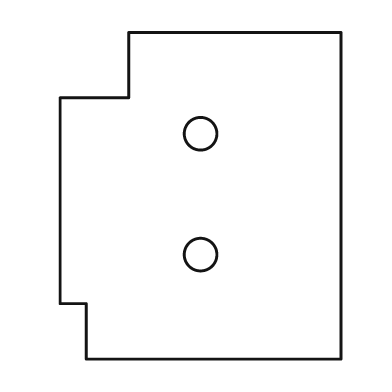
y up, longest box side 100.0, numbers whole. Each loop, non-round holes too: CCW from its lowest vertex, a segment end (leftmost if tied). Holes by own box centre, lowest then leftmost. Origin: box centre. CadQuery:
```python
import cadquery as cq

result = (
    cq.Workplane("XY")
    .moveTo(-35.0, -50.0)
    .lineTo(43.0, -50.0)
    .lineTo(43.0, 50.0)
    .lineTo(-22.0, 50.0)
    .lineTo(-22.0, 30.0)
    .lineTo(-43.0, 30.0)
    .lineTo(-43.0, -33.0)
    .lineTo(-35.0, -33.0)
    .close()
    .moveTo(0.0, -18.0)
    .circle(5.0)
    .moveTo(0.0, 19.0)
    .circle(5.0)
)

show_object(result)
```